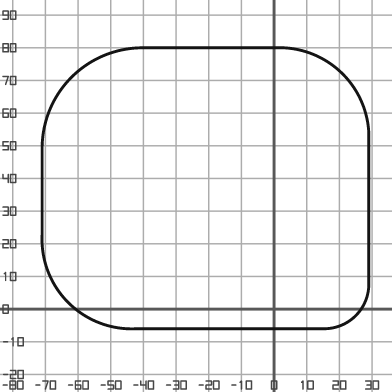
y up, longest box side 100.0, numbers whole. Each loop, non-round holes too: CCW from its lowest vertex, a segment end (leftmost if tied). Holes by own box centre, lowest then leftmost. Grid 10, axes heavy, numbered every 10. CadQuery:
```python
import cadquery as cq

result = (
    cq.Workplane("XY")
    .moveTo(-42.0, -6.0)
    .lineTo(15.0, -6.0)
    .threePointArc((25.0, -2.0), (29.0, 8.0))
    .lineTo(29.0, 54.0)
    .threePointArc((21.0, 72.0), (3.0, 80.0))
    .lineTo(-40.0, 80.0)
    .threePointArc((-62.0, 71.0), (-71.0, 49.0))
    .lineTo(-71.0, 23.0)
    .threePointArc((-63.0, 2.0), (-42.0, -6.0))
    .close()
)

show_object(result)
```